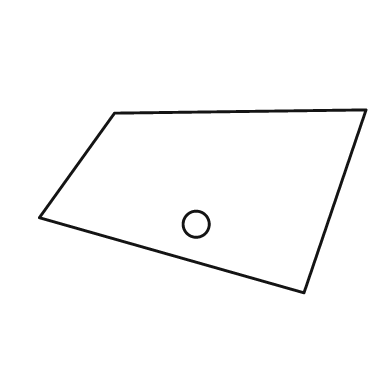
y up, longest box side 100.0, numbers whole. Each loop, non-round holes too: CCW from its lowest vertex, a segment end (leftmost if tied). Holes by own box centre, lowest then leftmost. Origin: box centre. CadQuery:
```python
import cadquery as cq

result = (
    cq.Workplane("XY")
    .moveTo(31.0, -28.0)
    .lineTo(50.0, 28.0)
    .lineTo(-27.0, 27.0)
    .lineTo(-50.0, -5.0)
    .close()
    .moveTo(-2.0, -7.0)
    .circle(4.0)
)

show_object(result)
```